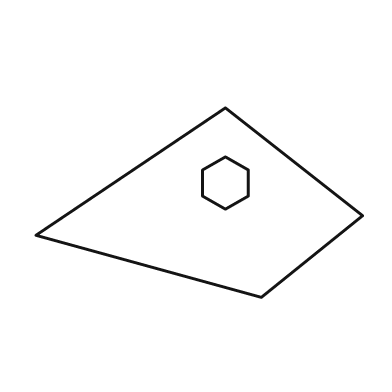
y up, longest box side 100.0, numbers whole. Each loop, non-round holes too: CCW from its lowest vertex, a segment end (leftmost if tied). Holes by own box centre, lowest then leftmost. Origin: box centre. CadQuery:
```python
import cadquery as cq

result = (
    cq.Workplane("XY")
    .moveTo(19.0, -29.0)
    .lineTo(50.0, -4.0)
    .lineTo(8.0, 29.0)
    .lineTo(-50.0, -10.0)
    .close()
    .moveTo(8.0, -2.0)
    .lineTo(15.0, 2.0)
    .lineTo(15.0, 10.0)
    .lineTo(8.0, 14.0)
    .lineTo(1.0, 10.0)
    .lineTo(1.0, 2.0)
    .close()
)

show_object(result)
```